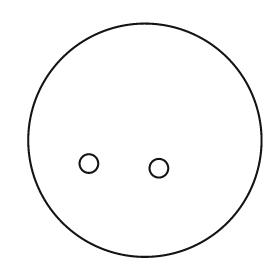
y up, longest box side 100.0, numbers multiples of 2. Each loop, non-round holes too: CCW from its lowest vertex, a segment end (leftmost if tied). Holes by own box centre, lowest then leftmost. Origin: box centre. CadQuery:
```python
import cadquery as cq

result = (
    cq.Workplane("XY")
    .moveTo(0.0, 0.0)
    .circle(50.0)
    .moveTo(6.0, -12.0)
    .circle(4.0)
    .moveTo(-24.0, -10.0)
    .circle(4.0)
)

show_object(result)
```